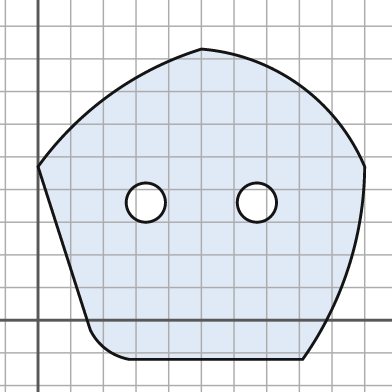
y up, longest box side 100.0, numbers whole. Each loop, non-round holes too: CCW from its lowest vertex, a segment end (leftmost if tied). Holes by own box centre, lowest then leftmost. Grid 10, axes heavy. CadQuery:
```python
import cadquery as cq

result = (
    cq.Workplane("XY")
    .moveTo(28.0, -12.0)
    .lineTo(81.0, -12.0)
    .threePointArc((95.0, 16.0), (100.0, 47.0))
    .threePointArc((80.0, 72.0), (50.0, 83.0))
    .threePointArc((22.0, 69.0), (0.0, 47.0))
    .lineTo(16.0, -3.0)
    .threePointArc((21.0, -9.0), (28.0, -12.0))
    .close()
    .moveTo(33.0, 36.0)
    .circle(6.0)
    .moveTo(67.0, 36.0)
    .circle(6.0)
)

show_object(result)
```